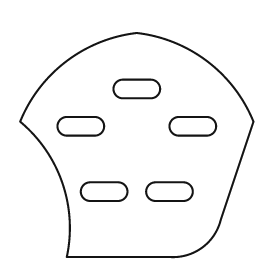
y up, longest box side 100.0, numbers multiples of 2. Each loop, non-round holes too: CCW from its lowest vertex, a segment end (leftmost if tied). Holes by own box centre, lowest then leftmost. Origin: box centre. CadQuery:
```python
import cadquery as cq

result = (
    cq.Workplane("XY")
    .moveTo(-30.0, -48.0)
    .lineTo(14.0, -48.0)
    .threePointArc((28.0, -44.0), (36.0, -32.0))
    .lineTo(50.0, 10.0)
    .threePointArc((30.0, 36.0), (0.0, 48.0))
    .threePointArc((-30.0, 36.0), (-50.0, 10.0))
    .threePointArc((-32.0, -16.0), (-30.0, -48.0))
    .close()
    .moveTo(-20.0, -24.0)
    .lineTo(-8.0, -24.0)
    .threePointArc((-4.0, -20.0), (-8.0, -16.0))
    .lineTo(-20.0, -16.0)
    .threePointArc((-24.0, -20.0), (-20.0, -24.0))
    .close()
    .moveTo(8.0, -24.0)
    .lineTo(20.0, -24.0)
    .threePointArc((24.0, -20.0), (20.0, -16.0))
    .lineTo(8.0, -16.0)
    .threePointArc((4.0, -20.0), (8.0, -24.0))
    .close()
    .moveTo(-30.0, 4.0)
    .lineTo(-18.0, 4.0)
    .threePointArc((-14.0, 8.0), (-18.0, 12.0))
    .lineTo(-30.0, 12.0)
    .threePointArc((-34.0, 8.0), (-30.0, 4.0))
    .close()
    .moveTo(18.0, 4.0)
    .lineTo(30.0, 4.0)
    .threePointArc((34.0, 8.0), (30.0, 12.0))
    .lineTo(18.0, 12.0)
    .threePointArc((14.0, 8.0), (18.0, 4.0))
    .close()
    .moveTo(-6.0, 20.0)
    .lineTo(6.0, 20.0)
    .threePointArc((10.0, 24.0), (6.0, 28.0))
    .lineTo(-6.0, 28.0)
    .threePointArc((-10.0, 24.0), (-6.0, 20.0))
    .close()
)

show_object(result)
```